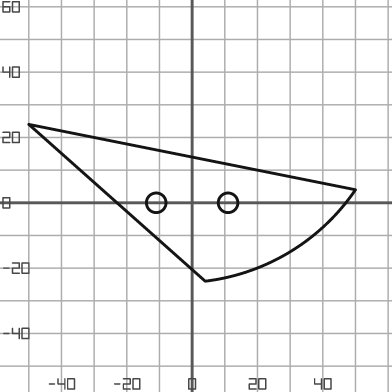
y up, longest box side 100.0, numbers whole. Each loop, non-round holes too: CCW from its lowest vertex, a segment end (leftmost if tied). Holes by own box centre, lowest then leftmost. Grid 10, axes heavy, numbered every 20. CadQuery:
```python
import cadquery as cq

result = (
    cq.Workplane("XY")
    .moveTo(4.0, -24.0)
    .threePointArc((30.0, -15.0), (50.0, 4.0))
    .lineTo(-50.0, 24.0)
    .close()
    .moveTo(-11.0, 0.0)
    .circle(3.0)
    .moveTo(11.0, 0.0)
    .circle(3.0)
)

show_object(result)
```